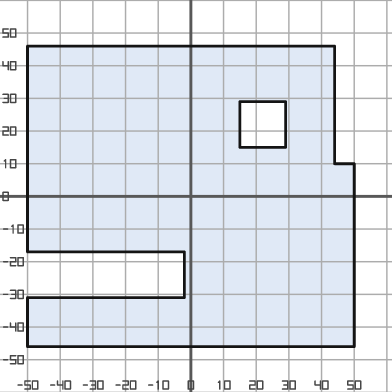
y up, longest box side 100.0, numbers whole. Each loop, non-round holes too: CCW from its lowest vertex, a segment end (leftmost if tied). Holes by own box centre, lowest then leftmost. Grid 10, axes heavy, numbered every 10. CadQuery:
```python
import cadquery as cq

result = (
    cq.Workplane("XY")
    .moveTo(-50.0, -46.0)
    .lineTo(50.0, -46.0)
    .lineTo(50.0, 10.0)
    .lineTo(44.0, 10.0)
    .lineTo(44.0, 46.0)
    .lineTo(-50.0, 46.0)
    .lineTo(-50.0, -17.0)
    .lineTo(-2.0, -17.0)
    .lineTo(-2.0, -31.0)
    .lineTo(-50.0, -31.0)
    .close()
    .moveTo(15.0, 15.0)
    .lineTo(29.0, 15.0)
    .lineTo(29.0, 29.0)
    .lineTo(15.0, 29.0)
    .close()
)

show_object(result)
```